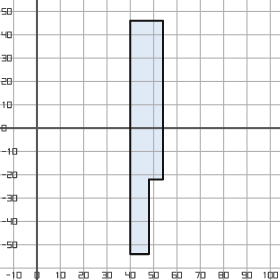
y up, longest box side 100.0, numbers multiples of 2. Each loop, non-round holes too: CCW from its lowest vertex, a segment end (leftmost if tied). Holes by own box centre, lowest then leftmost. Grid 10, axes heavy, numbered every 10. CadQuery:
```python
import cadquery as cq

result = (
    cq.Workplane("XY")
    .moveTo(40.0, -54.0)
    .lineTo(48.0, -54.0)
    .lineTo(48.0, -22.0)
    .lineTo(54.0, -22.0)
    .lineTo(54.0, 46.0)
    .lineTo(40.0, 46.0)
    .close()
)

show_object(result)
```